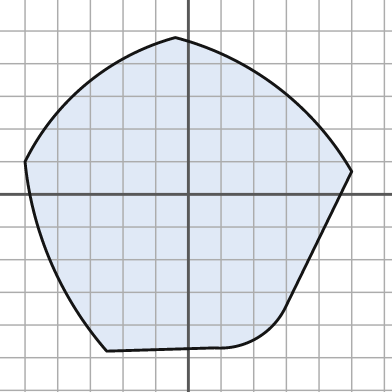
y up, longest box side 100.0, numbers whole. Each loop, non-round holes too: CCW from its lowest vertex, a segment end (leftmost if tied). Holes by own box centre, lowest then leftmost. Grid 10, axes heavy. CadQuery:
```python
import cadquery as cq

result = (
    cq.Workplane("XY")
    .moveTo(-25.0, -48.0)
    .lineTo(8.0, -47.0)
    .threePointArc((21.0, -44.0), (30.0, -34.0))
    .lineTo(50.0, 7.0)
    .threePointArc((27.0, 33.0), (-4.0, 48.0))
    .threePointArc((-31.0, 34.0), (-50.0, 10.0))
    .threePointArc((-42.0, -21.0), (-25.0, -48.0))
    .close()
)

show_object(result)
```